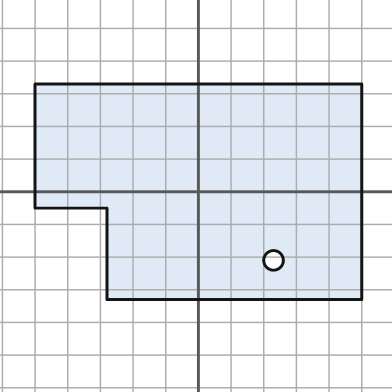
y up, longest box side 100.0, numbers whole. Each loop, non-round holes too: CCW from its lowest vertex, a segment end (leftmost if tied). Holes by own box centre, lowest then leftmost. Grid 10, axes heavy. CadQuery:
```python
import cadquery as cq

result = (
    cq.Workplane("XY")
    .moveTo(-28.0, -33.0)
    .lineTo(50.0, -33.0)
    .lineTo(50.0, 33.0)
    .lineTo(-50.0, 33.0)
    .lineTo(-50.0, -5.0)
    .lineTo(-28.0, -5.0)
    .close()
    .moveTo(23.0, -21.0)
    .circle(3.0)
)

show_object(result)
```